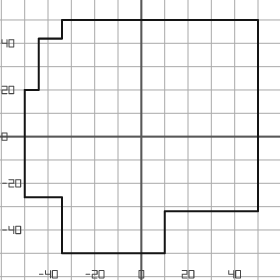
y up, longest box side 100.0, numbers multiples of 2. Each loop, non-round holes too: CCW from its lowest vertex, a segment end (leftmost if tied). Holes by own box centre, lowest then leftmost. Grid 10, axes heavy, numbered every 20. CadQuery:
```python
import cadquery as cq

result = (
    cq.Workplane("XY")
    .moveTo(-34.0, -50.0)
    .lineTo(10.0, -50.0)
    .lineTo(10.0, -32.0)
    .lineTo(50.0, -32.0)
    .lineTo(50.0, 50.0)
    .lineTo(-34.0, 50.0)
    .lineTo(-34.0, 42.0)
    .lineTo(-44.0, 42.0)
    .lineTo(-44.0, 20.0)
    .lineTo(-50.0, 20.0)
    .lineTo(-50.0, -26.0)
    .lineTo(-34.0, -26.0)
    .close()
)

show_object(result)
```